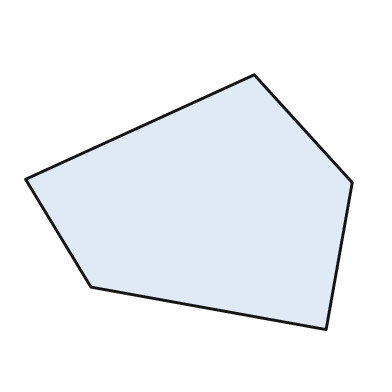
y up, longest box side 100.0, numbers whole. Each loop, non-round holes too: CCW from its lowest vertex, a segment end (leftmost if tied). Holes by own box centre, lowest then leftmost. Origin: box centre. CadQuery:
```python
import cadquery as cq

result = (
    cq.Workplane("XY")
    .moveTo(42.0, -39.0)
    .lineTo(50.0, 6.0)
    .lineTo(20.0, 39.0)
    .lineTo(-50.0, 7.0)
    .lineTo(-30.0, -26.0)
    .close()
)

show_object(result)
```